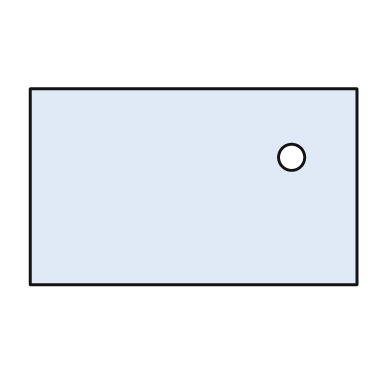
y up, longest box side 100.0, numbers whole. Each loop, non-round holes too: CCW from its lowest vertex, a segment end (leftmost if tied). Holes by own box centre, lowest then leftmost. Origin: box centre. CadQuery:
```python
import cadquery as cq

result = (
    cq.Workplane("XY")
    .moveTo(-50.0, -30.0)
    .lineTo(50.0, -30.0)
    .lineTo(50.0, 30.0)
    .lineTo(-50.0, 30.0)
    .close()
    .moveTo(30.0, 9.0)
    .circle(4.0)
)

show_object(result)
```